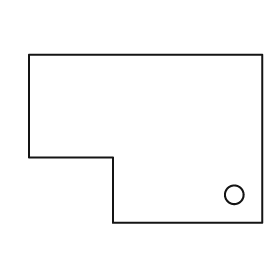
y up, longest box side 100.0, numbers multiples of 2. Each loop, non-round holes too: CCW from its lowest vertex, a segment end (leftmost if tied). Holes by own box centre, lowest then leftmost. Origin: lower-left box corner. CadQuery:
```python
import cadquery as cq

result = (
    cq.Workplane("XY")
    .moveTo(36.0, 0.0)
    .lineTo(100.0, 0.0)
    .lineTo(100.0, 72.0)
    .lineTo(0.0, 72.0)
    .lineTo(0.0, 28.0)
    .lineTo(36.0, 28.0)
    .close()
    .moveTo(88.0, 12.0)
    .circle(4.0)
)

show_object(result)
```